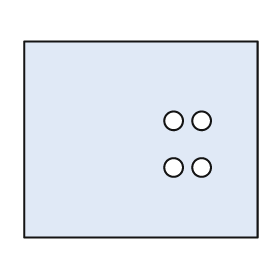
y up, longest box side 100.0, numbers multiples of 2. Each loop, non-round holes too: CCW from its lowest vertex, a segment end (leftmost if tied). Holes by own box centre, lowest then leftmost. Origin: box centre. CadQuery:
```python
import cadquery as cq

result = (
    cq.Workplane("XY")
    .moveTo(-50.0, -42.0)
    .lineTo(50.0, -42.0)
    .lineTo(50.0, 42.0)
    .lineTo(-50.0, 42.0)
    .close()
    .moveTo(14.0, -12.0)
    .circle(4.0)
    .moveTo(26.0, -12.0)
    .circle(4.0)
    .moveTo(14.0, 8.0)
    .circle(4.0)
    .moveTo(26.0, 8.0)
    .circle(4.0)
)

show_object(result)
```